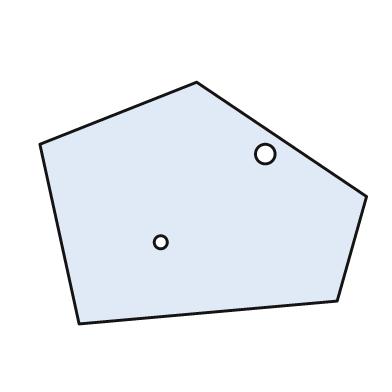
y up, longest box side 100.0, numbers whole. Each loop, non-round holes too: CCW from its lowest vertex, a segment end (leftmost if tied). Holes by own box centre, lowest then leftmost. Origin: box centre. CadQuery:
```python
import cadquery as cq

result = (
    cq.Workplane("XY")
    .moveTo(-38.0, -37.0)
    .lineTo(41.0, -30.0)
    .lineTo(50.0, 2.0)
    .lineTo(-2.0, 37.0)
    .lineTo(-50.0, 18.0)
    .close()
    .moveTo(-13.0, -12.0)
    .circle(2.0)
    .moveTo(19.0, 15.0)
    .circle(3.0)
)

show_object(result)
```